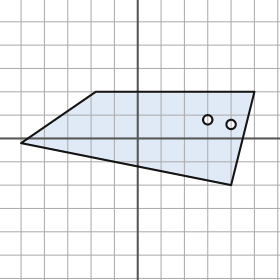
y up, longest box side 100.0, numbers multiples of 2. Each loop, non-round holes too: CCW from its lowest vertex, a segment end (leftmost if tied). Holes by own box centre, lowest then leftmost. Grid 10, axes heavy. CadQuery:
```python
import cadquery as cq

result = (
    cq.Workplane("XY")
    .moveTo(40.0, -20.0)
    .lineTo(50.0, 20.0)
    .lineTo(-18.0, 20.0)
    .lineTo(-50.0, -2.0)
    .close()
    .moveTo(40.0, 6.0)
    .circle(2.0)
    .moveTo(30.0, 8.0)
    .circle(2.0)
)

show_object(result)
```